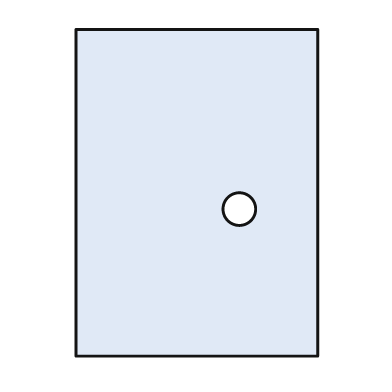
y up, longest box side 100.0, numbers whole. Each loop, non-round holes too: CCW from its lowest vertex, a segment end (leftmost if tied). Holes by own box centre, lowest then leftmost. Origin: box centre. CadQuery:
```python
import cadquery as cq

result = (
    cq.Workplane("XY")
    .moveTo(-37.0, -50.0)
    .lineTo(37.0, -50.0)
    .lineTo(37.0, 50.0)
    .lineTo(-37.0, 50.0)
    .close()
    .moveTo(13.0, -5.0)
    .circle(5.0)
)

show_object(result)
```